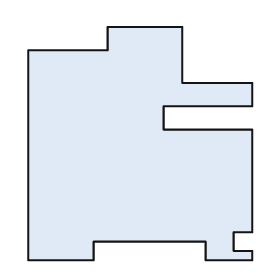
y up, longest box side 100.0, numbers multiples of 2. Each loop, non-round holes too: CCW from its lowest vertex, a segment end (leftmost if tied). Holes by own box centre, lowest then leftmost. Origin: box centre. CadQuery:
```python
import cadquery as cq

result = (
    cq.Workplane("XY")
    .moveTo(-48.0, -50.0)
    .lineTo(-20.0, -50.0)
    .lineTo(-20.0, -42.0)
    .lineTo(28.0, -42.0)
    .lineTo(28.0, -50.0)
    .lineTo(48.0, -50.0)
    .lineTo(48.0, -46.0)
    .lineTo(40.0, -46.0)
    .lineTo(40.0, -38.0)
    .lineTo(48.0, -38.0)
    .lineTo(48.0, 6.0)
    .lineTo(10.0, 6.0)
    .lineTo(10.0, 16.0)
    .lineTo(48.0, 16.0)
    .lineTo(48.0, 26.0)
    .lineTo(18.0, 26.0)
    .lineTo(18.0, 50.0)
    .lineTo(-14.0, 50.0)
    .lineTo(-14.0, 40.0)
    .lineTo(-48.0, 40.0)
    .close()
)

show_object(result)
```